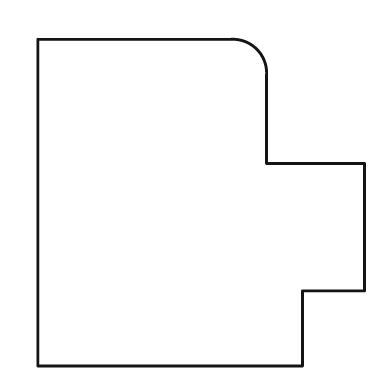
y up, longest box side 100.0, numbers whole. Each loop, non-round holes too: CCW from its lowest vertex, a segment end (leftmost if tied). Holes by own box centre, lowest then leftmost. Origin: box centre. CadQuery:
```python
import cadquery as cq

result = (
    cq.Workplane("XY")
    .moveTo(-50.0, -50.0)
    .lineTo(31.0, -50.0)
    .lineTo(31.0, -27.0)
    .lineTo(50.0, -27.0)
    .lineTo(50.0, 12.0)
    .lineTo(20.0, 12.0)
    .lineTo(20.0, 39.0)
    .threePointArc((17.0, 47.0), (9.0, 50.0))
    .lineTo(-50.0, 50.0)
    .close()
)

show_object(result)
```